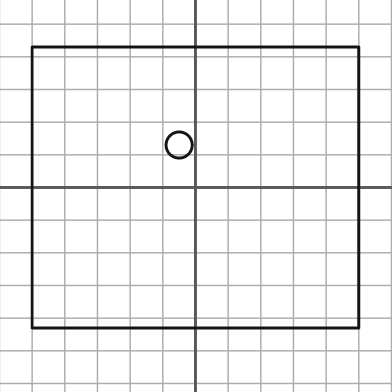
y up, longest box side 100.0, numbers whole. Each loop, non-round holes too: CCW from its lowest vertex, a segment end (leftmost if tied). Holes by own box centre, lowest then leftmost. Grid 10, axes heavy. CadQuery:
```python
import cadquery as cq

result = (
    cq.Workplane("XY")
    .moveTo(-50.0, -43.0)
    .lineTo(50.0, -43.0)
    .lineTo(50.0, 43.0)
    .lineTo(-50.0, 43.0)
    .close()
    .moveTo(-5.0, 13.0)
    .circle(4.0)
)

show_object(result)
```